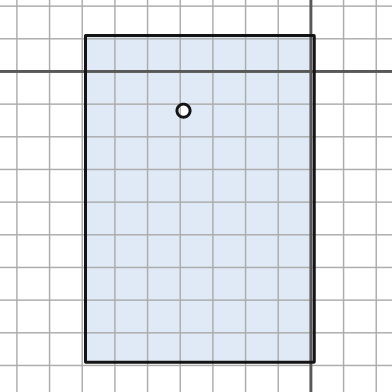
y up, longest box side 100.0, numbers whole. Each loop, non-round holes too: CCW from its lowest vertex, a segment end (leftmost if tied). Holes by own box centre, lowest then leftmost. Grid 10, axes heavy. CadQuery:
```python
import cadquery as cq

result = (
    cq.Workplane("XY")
    .moveTo(-69.0, -89.0)
    .lineTo(1.0, -89.0)
    .lineTo(1.0, 11.0)
    .lineTo(-69.0, 11.0)
    .close()
    .moveTo(-39.0, -12.0)
    .circle(2.0)
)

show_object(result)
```